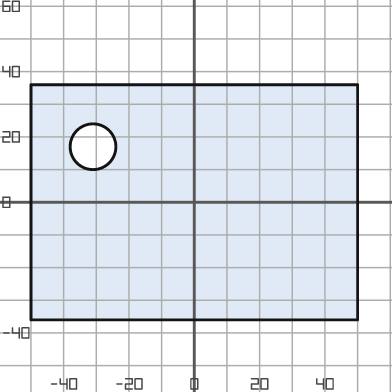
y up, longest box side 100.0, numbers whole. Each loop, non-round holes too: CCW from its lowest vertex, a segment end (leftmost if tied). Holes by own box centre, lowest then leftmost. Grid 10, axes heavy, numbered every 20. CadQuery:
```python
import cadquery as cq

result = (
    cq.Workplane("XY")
    .moveTo(-50.0, -36.0)
    .lineTo(50.0, -36.0)
    .lineTo(50.0, 36.0)
    .lineTo(-50.0, 36.0)
    .close()
    .moveTo(-31.0, 17.0)
    .circle(7.0)
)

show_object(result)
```